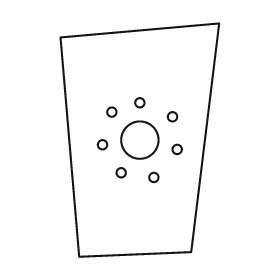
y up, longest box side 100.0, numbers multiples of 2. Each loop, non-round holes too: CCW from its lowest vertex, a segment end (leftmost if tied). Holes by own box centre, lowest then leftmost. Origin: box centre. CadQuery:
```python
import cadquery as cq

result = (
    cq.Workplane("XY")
    .moveTo(-26.0, -50.0)
    .lineTo(22.0, -48.0)
    .lineTo(34.0, 50.0)
    .lineTo(-34.0, 44.0)
    .close()
    .moveTo(6.0, -16.0)
    .circle(2.0)
    .moveTo(-8.0, -14.0)
    .circle(2.0)
    .moveTo(16.0, -4.0)
    .circle(2.0)
    .moveTo(-16.0, -2.0)
    .circle(2.0)
    .moveTo(0.0, 0.0)
    .circle(8.0)
    .moveTo(14.0, 10.0)
    .circle(2.0)
    .moveTo(-12.0, 12.0)
    .circle(2.0)
    .moveTo(0.0, 16.0)
    .circle(2.0)
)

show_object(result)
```